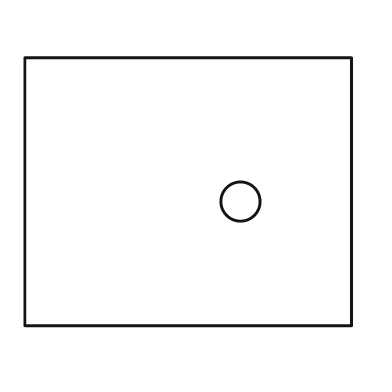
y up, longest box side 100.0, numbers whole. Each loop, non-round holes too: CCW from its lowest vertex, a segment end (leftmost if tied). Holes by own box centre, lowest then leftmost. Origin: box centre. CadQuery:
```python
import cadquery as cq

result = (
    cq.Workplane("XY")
    .moveTo(-50.0, -41.0)
    .lineTo(50.0, -41.0)
    .lineTo(50.0, 41.0)
    .lineTo(-50.0, 41.0)
    .close()
    .moveTo(16.0, -3.0)
    .circle(6.0)
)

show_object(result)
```